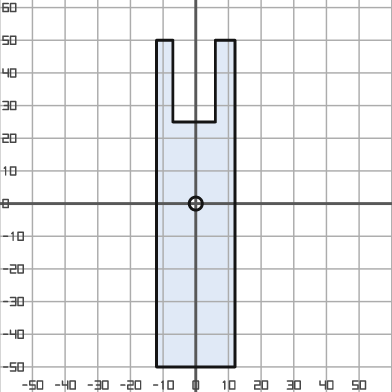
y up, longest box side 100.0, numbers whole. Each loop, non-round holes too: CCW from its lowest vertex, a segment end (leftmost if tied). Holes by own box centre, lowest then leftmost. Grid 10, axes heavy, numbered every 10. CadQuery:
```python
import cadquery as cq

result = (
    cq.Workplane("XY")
    .moveTo(-12.0, -50.0)
    .lineTo(12.0, -50.0)
    .lineTo(12.0, 50.0)
    .lineTo(6.0, 50.0)
    .lineTo(6.0, 25.0)
    .lineTo(-7.0, 25.0)
    .lineTo(-7.0, 50.0)
    .lineTo(-12.0, 50.0)
    .close()
    .moveTo(0.0, 0.0)
    .circle(2.0)
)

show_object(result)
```